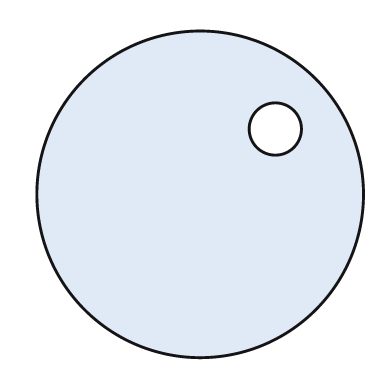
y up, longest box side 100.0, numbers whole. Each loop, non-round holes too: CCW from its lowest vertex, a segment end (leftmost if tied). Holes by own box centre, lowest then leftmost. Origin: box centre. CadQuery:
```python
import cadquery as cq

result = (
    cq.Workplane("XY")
    .moveTo(0.0, 0.0)
    .circle(50.0)
    .moveTo(23.0, 20.0)
    .circle(8.0)
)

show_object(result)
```